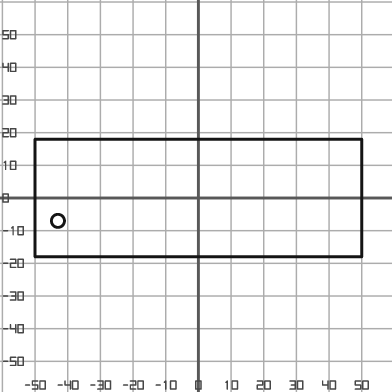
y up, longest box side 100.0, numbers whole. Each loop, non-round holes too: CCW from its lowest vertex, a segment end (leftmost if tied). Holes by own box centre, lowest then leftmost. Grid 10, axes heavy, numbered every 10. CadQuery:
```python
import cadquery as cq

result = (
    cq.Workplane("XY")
    .moveTo(-50.0, -18.0)
    .lineTo(50.0, -18.0)
    .lineTo(50.0, 18.0)
    .lineTo(-50.0, 18.0)
    .close()
    .moveTo(-43.0, -7.0)
    .circle(2.0)
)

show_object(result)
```